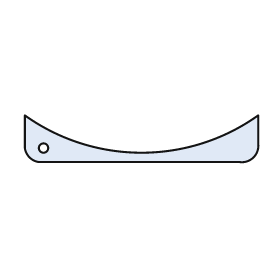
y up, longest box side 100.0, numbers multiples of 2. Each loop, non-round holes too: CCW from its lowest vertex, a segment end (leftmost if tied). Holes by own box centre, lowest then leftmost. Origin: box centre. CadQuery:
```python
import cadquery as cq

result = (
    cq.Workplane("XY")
    .moveTo(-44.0, -10.0)
    .lineTo(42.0, -10.0)
    .threePointArc((48.0, -8.0), (50.0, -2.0))
    .lineTo(50.0, 10.0)
    .threePointArc((0.0, -6.0), (-50.0, 10.0))
    .lineTo(-50.0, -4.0)
    .threePointArc((-48.0, -8.0), (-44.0, -10.0))
    .close()
    .moveTo(-42.0, -4.0)
    .circle(2.0)
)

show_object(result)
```